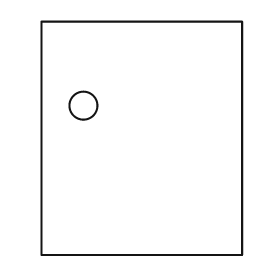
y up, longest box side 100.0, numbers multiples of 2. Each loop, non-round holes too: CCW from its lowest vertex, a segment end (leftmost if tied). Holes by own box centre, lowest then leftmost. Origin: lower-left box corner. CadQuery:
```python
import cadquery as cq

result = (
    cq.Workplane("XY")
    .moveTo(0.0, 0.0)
    .lineTo(86.0, 0.0)
    .lineTo(86.0, 100.0)
    .lineTo(0.0, 100.0)
    .close()
    .moveTo(18.0, 64.0)
    .circle(6.0)
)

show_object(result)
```